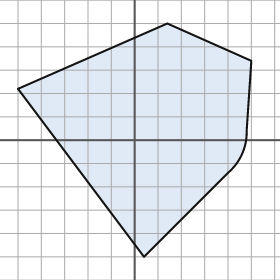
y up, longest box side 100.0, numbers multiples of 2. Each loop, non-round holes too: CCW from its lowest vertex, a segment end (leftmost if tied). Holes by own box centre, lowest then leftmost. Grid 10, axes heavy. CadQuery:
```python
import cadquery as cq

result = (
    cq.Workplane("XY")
    .moveTo(4.0, -50.0)
    .lineTo(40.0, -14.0)
    .threePointArc((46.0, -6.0), (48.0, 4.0))
    .lineTo(50.0, 34.0)
    .lineTo(14.0, 50.0)
    .lineTo(-50.0, 22.0)
    .close()
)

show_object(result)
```